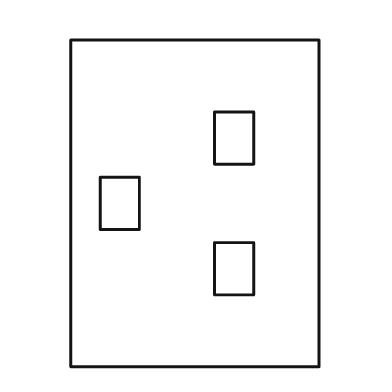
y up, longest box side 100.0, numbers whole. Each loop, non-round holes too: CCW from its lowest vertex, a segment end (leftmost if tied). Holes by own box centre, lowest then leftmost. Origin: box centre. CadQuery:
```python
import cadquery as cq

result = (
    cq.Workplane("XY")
    .moveTo(-38.0, -50.0)
    .lineTo(38.0, -50.0)
    .lineTo(38.0, 50.0)
    .lineTo(-38.0, 50.0)
    .close()
    .moveTo(6.0, -28.0)
    .lineTo(18.0, -28.0)
    .lineTo(18.0, -12.0)
    .lineTo(6.0, -12.0)
    .close()
    .moveTo(-29.0, -8.0)
    .lineTo(-17.0, -8.0)
    .lineTo(-17.0, 8.0)
    .lineTo(-29.0, 8.0)
    .close()
    .moveTo(6.0, 12.0)
    .lineTo(18.0, 12.0)
    .lineTo(18.0, 28.0)
    .lineTo(6.0, 28.0)
    .close()
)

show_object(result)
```